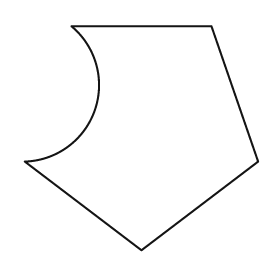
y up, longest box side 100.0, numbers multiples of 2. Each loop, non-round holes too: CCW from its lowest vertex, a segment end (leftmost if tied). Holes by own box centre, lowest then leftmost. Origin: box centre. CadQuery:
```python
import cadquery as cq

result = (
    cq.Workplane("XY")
    .moveTo(0.0, -48.0)
    .lineTo(50.0, -10.0)
    .lineTo(30.0, 48.0)
    .lineTo(-30.0, 48.0)
    .threePointArc((-20.0, 12.0), (-50.0, -10.0))
    .close()
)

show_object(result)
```